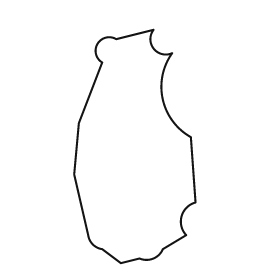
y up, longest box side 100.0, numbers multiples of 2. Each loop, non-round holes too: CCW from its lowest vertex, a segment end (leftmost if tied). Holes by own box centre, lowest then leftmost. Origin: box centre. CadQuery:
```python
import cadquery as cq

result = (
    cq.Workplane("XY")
    .moveTo(-6.0, -50.0)
    .lineTo(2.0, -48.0)
    .threePointArc((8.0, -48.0), (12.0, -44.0))
    .lineTo(22.0, -38.0)
    .threePointArc((20.0, -30.0), (26.0, -24.0))
    .lineTo(24.0, 4.0)
    .threePointArc((12.0, 20.0), (16.0, 40.0))
    .threePointArc((8.0, 42.0), (8.0, 50.0))
    .lineTo(-8.0, 46.0)
    .threePointArc((-16.0, 44.0), (-14.0, 36.0))
    .lineTo(-24.0, 10.0)
    .lineTo(-26.0, -12.0)
    .lineTo(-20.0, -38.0)
    .threePointArc((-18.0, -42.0), (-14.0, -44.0))
    .close()
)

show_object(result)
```